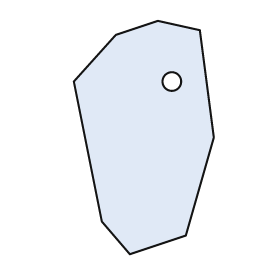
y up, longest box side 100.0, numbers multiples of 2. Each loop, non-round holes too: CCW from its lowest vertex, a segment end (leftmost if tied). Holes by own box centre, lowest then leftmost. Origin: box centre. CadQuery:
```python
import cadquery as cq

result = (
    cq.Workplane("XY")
    .moveTo(-6.0, -50.0)
    .lineTo(18.0, -42.0)
    .lineTo(30.0, 0.0)
    .lineTo(24.0, 46.0)
    .lineTo(6.0, 50.0)
    .lineTo(-12.0, 44.0)
    .lineTo(-30.0, 24.0)
    .lineTo(-18.0, -36.0)
    .close()
    .moveTo(12.0, 24.0)
    .circle(4.0)
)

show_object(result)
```